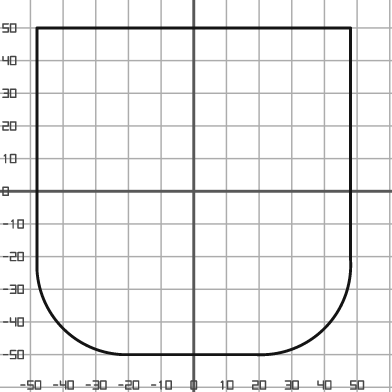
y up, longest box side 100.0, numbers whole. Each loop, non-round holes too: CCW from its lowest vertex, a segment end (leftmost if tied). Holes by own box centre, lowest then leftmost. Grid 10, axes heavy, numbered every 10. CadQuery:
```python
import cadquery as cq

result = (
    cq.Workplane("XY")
    .moveTo(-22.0, -50.0)
    .lineTo(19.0, -50.0)
    .threePointArc((40.0, -42.0), (48.0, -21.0))
    .lineTo(48.0, 50.0)
    .lineTo(-48.0, 50.0)
    .lineTo(-48.0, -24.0)
    .threePointArc((-40.0, -42.0), (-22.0, -50.0))
    .close()
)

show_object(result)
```